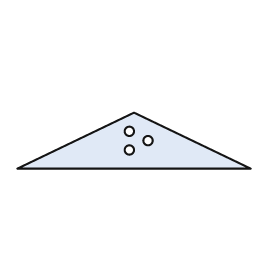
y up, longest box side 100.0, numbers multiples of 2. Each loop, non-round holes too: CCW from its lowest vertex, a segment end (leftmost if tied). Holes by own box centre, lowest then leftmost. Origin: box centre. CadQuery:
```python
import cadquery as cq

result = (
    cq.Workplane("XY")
    .moveTo(-50.0, -12.0)
    .lineTo(50.0, -12.0)
    .lineTo(0.0, 12.0)
    .close()
    .moveTo(-2.0, -4.0)
    .circle(2.0)
    .moveTo(6.0, 0.0)
    .circle(2.0)
    .moveTo(-2.0, 4.0)
    .circle(2.0)
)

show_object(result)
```